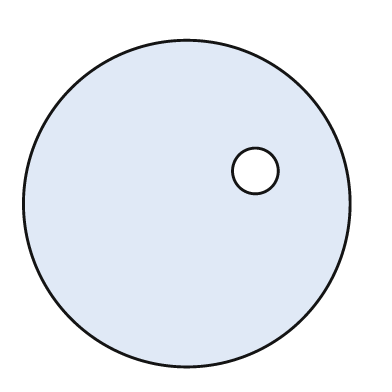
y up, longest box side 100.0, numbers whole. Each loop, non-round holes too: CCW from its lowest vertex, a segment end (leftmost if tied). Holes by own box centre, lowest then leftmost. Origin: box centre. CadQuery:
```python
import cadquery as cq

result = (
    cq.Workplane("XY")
    .moveTo(0.0, 0.0)
    .circle(50.0)
    .moveTo(21.0, 10.0)
    .circle(7.0)
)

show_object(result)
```